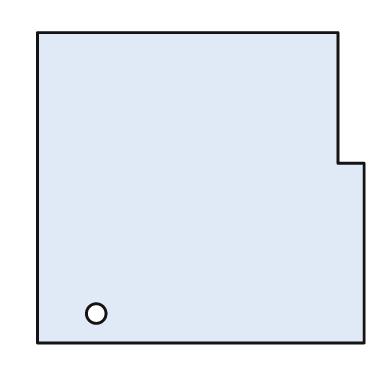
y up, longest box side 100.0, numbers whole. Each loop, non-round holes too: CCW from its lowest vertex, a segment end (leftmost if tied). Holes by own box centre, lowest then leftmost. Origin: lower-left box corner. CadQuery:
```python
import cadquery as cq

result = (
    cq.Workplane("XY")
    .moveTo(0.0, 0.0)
    .lineTo(100.0, 0.0)
    .lineTo(100.0, 55.0)
    .lineTo(92.0, 55.0)
    .lineTo(92.0, 95.0)
    .lineTo(0.0, 95.0)
    .close()
    .moveTo(18.0, 9.0)
    .circle(3.0)
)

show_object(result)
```